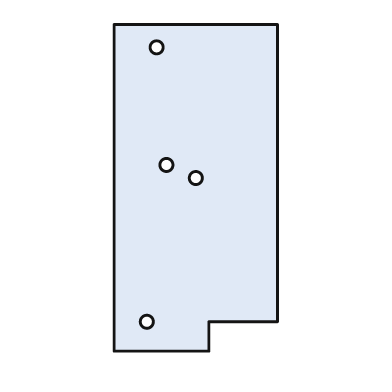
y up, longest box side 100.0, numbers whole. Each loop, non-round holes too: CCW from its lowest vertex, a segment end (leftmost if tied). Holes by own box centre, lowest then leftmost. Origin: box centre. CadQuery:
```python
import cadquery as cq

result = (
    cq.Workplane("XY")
    .moveTo(-25.0, -50.0)
    .lineTo(4.0, -50.0)
    .lineTo(4.0, -41.0)
    .lineTo(25.0, -41.0)
    .lineTo(25.0, 50.0)
    .lineTo(-25.0, 50.0)
    .close()
    .moveTo(-15.0, -41.0)
    .circle(2.0)
    .moveTo(0.0, 3.0)
    .circle(2.0)
    .moveTo(-9.0, 7.0)
    .circle(2.0)
    .moveTo(-12.0, 43.0)
    .circle(2.0)
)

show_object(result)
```